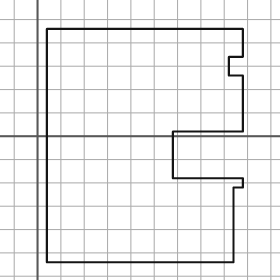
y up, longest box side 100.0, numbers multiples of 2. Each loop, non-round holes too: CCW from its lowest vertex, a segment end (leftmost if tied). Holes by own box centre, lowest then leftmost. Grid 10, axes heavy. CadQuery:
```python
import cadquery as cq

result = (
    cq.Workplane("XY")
    .moveTo(4.0, -54.0)
    .lineTo(84.0, -54.0)
    .lineTo(84.0, -22.0)
    .lineTo(88.0, -22.0)
    .lineTo(88.0, -18.0)
    .lineTo(58.0, -18.0)
    .lineTo(58.0, 2.0)
    .lineTo(88.0, 2.0)
    .lineTo(88.0, 26.0)
    .lineTo(82.0, 26.0)
    .lineTo(82.0, 34.0)
    .lineTo(88.0, 34.0)
    .lineTo(88.0, 46.0)
    .lineTo(4.0, 46.0)
    .close()
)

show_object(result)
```